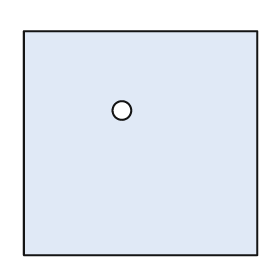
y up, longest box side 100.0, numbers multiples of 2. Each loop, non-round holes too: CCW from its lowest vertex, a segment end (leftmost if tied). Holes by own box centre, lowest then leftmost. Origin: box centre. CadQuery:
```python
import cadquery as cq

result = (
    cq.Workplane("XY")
    .moveTo(-50.0, -48.0)
    .lineTo(50.0, -48.0)
    .lineTo(50.0, 48.0)
    .lineTo(-50.0, 48.0)
    .close()
    .moveTo(-8.0, 14.0)
    .circle(4.0)
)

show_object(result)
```